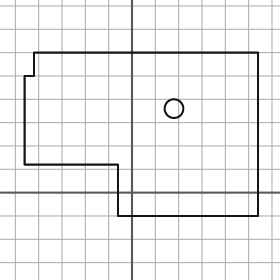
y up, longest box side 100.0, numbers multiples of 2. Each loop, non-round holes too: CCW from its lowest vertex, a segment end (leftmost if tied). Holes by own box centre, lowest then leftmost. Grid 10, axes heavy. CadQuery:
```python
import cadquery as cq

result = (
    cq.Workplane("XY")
    .moveTo(-6.0, -10.0)
    .lineTo(54.0, -10.0)
    .lineTo(54.0, 60.0)
    .lineTo(-42.0, 60.0)
    .lineTo(-42.0, 50.0)
    .lineTo(-46.0, 50.0)
    .lineTo(-46.0, 12.0)
    .lineTo(-6.0, 12.0)
    .close()
    .moveTo(18.0, 36.0)
    .circle(4.0)
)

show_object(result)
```